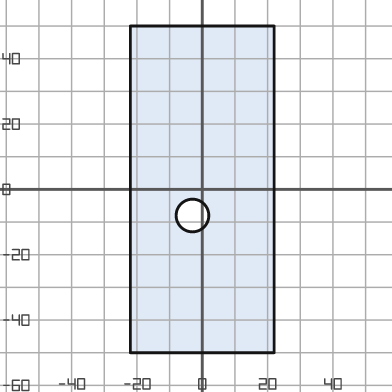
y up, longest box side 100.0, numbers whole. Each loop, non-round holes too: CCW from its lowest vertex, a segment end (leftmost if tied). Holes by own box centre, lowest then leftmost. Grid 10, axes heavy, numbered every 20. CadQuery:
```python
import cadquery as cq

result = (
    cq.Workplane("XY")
    .moveTo(-22.0, -50.0)
    .lineTo(22.0, -50.0)
    .lineTo(22.0, 50.0)
    .lineTo(-22.0, 50.0)
    .close()
    .moveTo(-3.0, -8.0)
    .circle(5.0)
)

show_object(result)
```